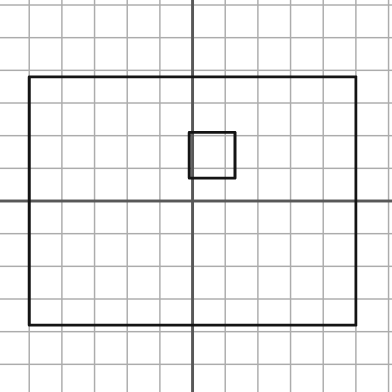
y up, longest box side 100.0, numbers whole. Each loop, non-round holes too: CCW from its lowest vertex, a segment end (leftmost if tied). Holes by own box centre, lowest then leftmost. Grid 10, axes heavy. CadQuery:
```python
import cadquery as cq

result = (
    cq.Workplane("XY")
    .moveTo(-50.0, -38.0)
    .lineTo(50.0, -38.0)
    .lineTo(50.0, 38.0)
    .lineTo(-50.0, 38.0)
    .close()
    .moveTo(-1.0, 7.0)
    .lineTo(13.0, 7.0)
    .lineTo(13.0, 21.0)
    .lineTo(-1.0, 21.0)
    .close()
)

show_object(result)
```